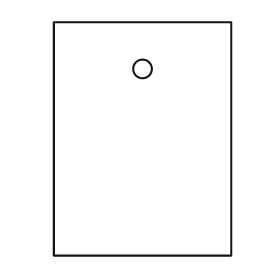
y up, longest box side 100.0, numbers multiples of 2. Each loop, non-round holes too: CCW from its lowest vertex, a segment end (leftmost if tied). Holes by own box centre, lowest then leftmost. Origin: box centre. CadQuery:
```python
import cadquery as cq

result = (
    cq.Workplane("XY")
    .moveTo(-38.0, -50.0)
    .lineTo(38.0, -50.0)
    .lineTo(38.0, 50.0)
    .lineTo(-38.0, 50.0)
    .close()
    .moveTo(0.0, 30.0)
    .circle(4.0)
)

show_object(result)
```